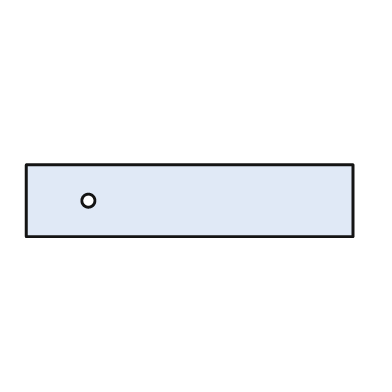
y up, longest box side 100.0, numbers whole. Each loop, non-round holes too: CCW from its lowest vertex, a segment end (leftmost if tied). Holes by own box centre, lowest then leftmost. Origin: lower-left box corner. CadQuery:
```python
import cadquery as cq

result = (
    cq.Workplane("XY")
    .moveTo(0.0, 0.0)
    .lineTo(100.0, 0.0)
    .lineTo(100.0, 22.0)
    .lineTo(0.0, 22.0)
    .close()
    .moveTo(19.0, 11.0)
    .circle(2.0)
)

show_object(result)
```